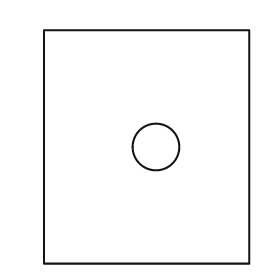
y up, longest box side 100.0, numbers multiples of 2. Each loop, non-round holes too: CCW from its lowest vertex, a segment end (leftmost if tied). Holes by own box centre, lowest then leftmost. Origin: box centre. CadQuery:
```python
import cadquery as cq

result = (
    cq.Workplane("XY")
    .moveTo(-44.0, -50.0)
    .lineTo(44.0, -50.0)
    .lineTo(44.0, 50.0)
    .lineTo(-44.0, 50.0)
    .close()
    .moveTo(4.0, 0.0)
    .circle(10.0)
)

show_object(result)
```